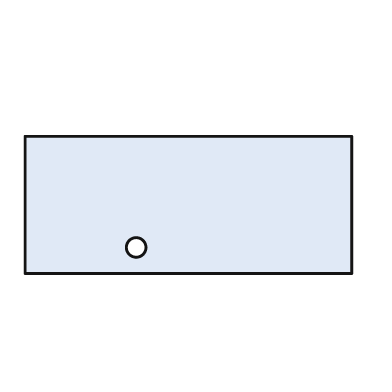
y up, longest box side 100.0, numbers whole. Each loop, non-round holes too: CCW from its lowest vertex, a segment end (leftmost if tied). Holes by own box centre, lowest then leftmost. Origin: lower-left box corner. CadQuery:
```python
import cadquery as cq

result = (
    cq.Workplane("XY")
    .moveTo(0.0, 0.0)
    .lineTo(100.0, 0.0)
    .lineTo(100.0, 42.0)
    .lineTo(0.0, 42.0)
    .close()
    .moveTo(34.0, 8.0)
    .circle(3.0)
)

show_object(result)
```